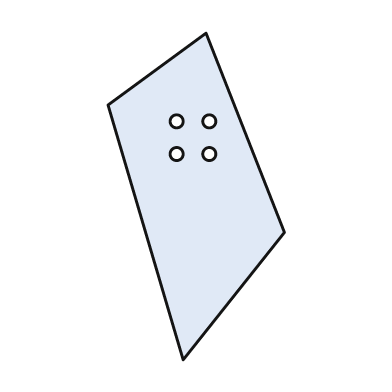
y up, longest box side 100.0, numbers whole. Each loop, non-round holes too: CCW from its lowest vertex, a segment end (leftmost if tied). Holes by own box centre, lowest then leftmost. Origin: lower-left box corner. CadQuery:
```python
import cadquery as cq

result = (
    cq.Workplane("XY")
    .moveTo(23.0, 0.0)
    .lineTo(54.0, 39.0)
    .lineTo(30.0, 100.0)
    .lineTo(0.0, 78.0)
    .close()
    .moveTo(21.0, 63.0)
    .circle(2.0)
    .moveTo(31.0, 63.0)
    .circle(2.0)
    .moveTo(21.0, 73.0)
    .circle(2.0)
    .moveTo(31.0, 73.0)
    .circle(2.0)
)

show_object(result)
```